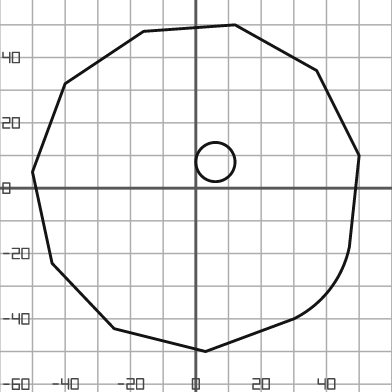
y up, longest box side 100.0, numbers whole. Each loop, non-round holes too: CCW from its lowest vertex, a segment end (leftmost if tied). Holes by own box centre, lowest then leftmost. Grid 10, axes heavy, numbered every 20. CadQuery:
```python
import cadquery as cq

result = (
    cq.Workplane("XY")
    .moveTo(3.0, -50.0)
    .lineTo(30.0, -40.0)
    .threePointArc((41.0, -31.0), (47.0, -18.0))
    .lineTo(50.0, 10.0)
    .lineTo(37.0, 36.0)
    .lineTo(12.0, 50.0)
    .lineTo(-16.0, 48.0)
    .lineTo(-40.0, 32.0)
    .lineTo(-50.0, 5.0)
    .lineTo(-44.0, -23.0)
    .lineTo(-25.0, -43.0)
    .close()
    .moveTo(6.0, 8.0)
    .circle(6.0)
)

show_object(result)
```